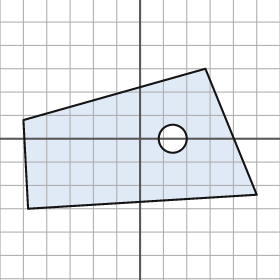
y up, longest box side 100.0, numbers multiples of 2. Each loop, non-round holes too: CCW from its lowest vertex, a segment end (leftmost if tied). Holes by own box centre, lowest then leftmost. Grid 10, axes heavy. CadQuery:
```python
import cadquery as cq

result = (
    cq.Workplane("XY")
    .moveTo(-48.0, -30.0)
    .lineTo(50.0, -24.0)
    .lineTo(28.0, 30.0)
    .lineTo(-50.0, 8.0)
    .close()
    .moveTo(14.0, 0.0)
    .circle(6.0)
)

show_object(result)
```